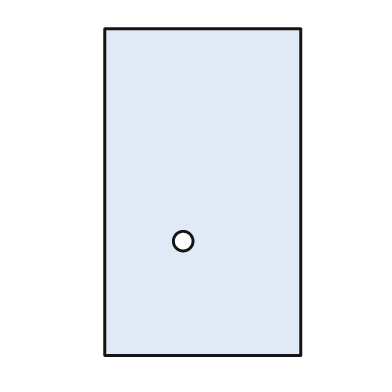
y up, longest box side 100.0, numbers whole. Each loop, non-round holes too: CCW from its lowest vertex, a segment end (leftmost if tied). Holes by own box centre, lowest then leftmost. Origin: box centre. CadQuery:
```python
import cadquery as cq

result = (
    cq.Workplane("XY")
    .moveTo(-30.0, -50.0)
    .lineTo(30.0, -50.0)
    .lineTo(30.0, 50.0)
    .lineTo(-30.0, 50.0)
    .close()
    .moveTo(-6.0, -15.0)
    .circle(3.0)
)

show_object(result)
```